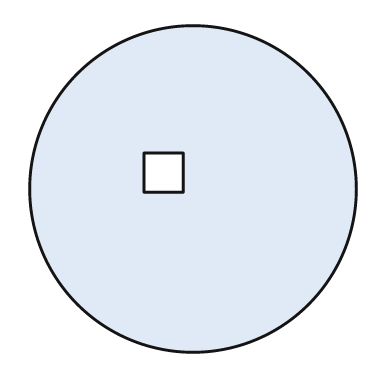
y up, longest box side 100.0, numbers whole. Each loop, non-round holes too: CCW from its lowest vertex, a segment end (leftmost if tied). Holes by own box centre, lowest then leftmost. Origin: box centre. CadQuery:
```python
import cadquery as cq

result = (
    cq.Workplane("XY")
    .moveTo(0.0, 0.0)
    .circle(50.0)
    .moveTo(-15.0, -1.0)
    .lineTo(-3.0, -1.0)
    .lineTo(-3.0, 11.0)
    .lineTo(-15.0, 11.0)
    .close()
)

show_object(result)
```